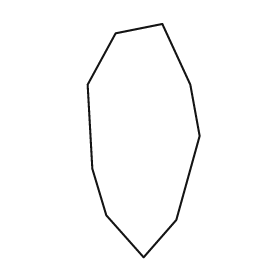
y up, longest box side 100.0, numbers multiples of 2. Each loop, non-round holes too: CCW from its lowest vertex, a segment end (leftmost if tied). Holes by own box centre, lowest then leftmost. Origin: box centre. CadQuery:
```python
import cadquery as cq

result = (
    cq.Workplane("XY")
    .moveTo(0.0, -50.0)
    .lineTo(14.0, -34.0)
    .lineTo(24.0, 2.0)
    .lineTo(20.0, 24.0)
    .lineTo(8.0, 50.0)
    .lineTo(-12.0, 46.0)
    .lineTo(-24.0, 24.0)
    .lineTo(-22.0, -12.0)
    .lineTo(-16.0, -32.0)
    .close()
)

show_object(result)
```